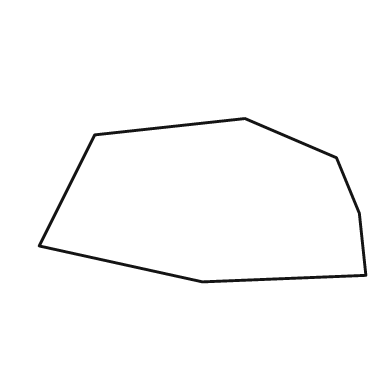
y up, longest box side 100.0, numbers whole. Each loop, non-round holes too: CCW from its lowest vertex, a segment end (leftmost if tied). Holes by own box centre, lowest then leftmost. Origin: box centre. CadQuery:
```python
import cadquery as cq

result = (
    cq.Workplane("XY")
    .moveTo(0.0, -25.0)
    .lineTo(50.0, -23.0)
    .lineTo(48.0, -4.0)
    .lineTo(41.0, 13.0)
    .lineTo(13.0, 25.0)
    .lineTo(-33.0, 20.0)
    .lineTo(-50.0, -14.0)
    .close()
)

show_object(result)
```